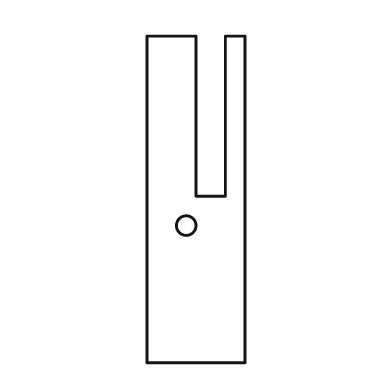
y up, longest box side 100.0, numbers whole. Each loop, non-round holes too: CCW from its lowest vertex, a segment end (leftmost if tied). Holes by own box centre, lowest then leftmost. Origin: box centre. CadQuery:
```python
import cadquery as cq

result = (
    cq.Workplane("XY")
    .moveTo(-15.0, -50.0)
    .lineTo(15.0, -50.0)
    .lineTo(15.0, 50.0)
    .lineTo(9.0, 50.0)
    .lineTo(9.0, 1.0)
    .lineTo(0.0, 1.0)
    .lineTo(0.0, 50.0)
    .lineTo(-15.0, 50.0)
    .close()
    .moveTo(-3.0, -8.0)
    .circle(3.0)
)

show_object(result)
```